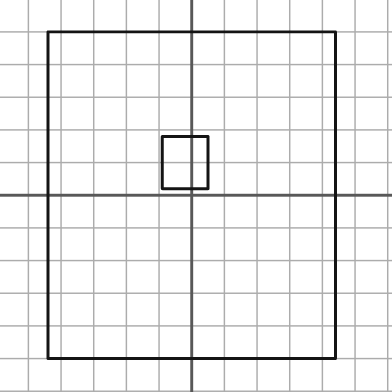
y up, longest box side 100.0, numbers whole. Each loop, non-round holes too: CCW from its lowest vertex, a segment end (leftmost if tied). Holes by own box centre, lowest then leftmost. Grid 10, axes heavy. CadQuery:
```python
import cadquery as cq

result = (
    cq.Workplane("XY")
    .moveTo(-44.0, -50.0)
    .lineTo(44.0, -50.0)
    .lineTo(44.0, 50.0)
    .lineTo(-44.0, 50.0)
    .close()
    .moveTo(-9.0, 2.0)
    .lineTo(5.0, 2.0)
    .lineTo(5.0, 18.0)
    .lineTo(-9.0, 18.0)
    .close()
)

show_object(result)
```